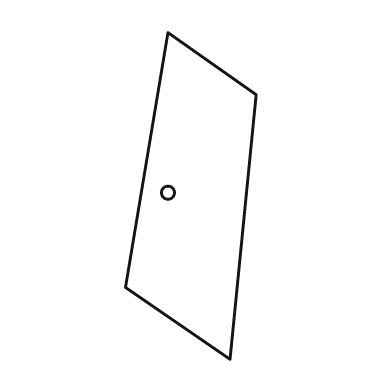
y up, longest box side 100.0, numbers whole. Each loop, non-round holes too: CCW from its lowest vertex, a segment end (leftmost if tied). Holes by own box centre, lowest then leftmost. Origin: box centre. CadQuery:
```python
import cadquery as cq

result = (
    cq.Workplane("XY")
    .moveTo(12.0, -50.0)
    .lineTo(20.0, 31.0)
    .lineTo(-7.0, 50.0)
    .lineTo(-20.0, -28.0)
    .close()
    .moveTo(-7.0, 1.0)
    .circle(2.0)
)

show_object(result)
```